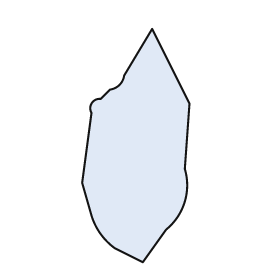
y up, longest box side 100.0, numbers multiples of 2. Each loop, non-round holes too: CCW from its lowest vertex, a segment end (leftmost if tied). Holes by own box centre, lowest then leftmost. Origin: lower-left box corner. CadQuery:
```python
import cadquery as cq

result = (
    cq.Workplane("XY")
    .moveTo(26.0, 0.0)
    .lineTo(36.0, 14.0)
    .threePointArc((44.0, 26.0), (44.0, 40.0))
    .lineTo(46.0, 68.0)
    .lineTo(30.0, 100.0)
    .lineTo(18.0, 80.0)
    .threePointArc((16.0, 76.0), (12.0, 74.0))
    .lineTo(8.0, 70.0)
    .threePointArc((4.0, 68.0), (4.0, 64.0))
    .lineTo(0.0, 34.0)
    .lineTo(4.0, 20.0)
    .threePointArc((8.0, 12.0), (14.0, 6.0))
    .close()
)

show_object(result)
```